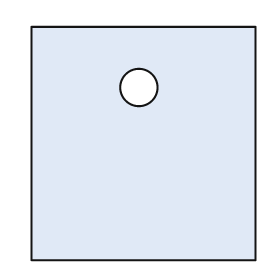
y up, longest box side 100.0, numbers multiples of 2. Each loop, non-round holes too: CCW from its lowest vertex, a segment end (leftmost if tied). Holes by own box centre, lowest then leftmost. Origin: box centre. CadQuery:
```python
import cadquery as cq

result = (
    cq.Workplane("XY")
    .moveTo(-48.0, -50.0)
    .lineTo(48.0, -50.0)
    .lineTo(48.0, 50.0)
    .lineTo(-48.0, 50.0)
    .close()
    .moveTo(-2.0, 24.0)
    .circle(8.0)
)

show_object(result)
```